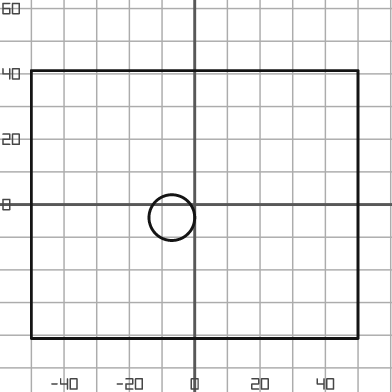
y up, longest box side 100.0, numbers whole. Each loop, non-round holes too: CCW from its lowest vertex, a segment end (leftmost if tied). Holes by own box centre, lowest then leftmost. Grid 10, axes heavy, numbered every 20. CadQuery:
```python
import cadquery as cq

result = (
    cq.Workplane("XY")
    .moveTo(-50.0, -41.0)
    .lineTo(50.0, -41.0)
    .lineTo(50.0, 41.0)
    .lineTo(-50.0, 41.0)
    .close()
    .moveTo(-7.0, -4.0)
    .circle(7.0)
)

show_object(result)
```